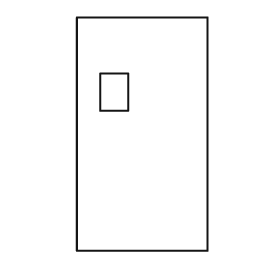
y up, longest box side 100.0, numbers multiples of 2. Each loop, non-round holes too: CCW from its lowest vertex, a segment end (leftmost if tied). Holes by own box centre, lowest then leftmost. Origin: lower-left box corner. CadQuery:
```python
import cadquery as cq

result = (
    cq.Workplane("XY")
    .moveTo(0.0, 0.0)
    .lineTo(56.0, 0.0)
    .lineTo(56.0, 100.0)
    .lineTo(0.0, 100.0)
    .close()
    .moveTo(10.0, 60.0)
    .lineTo(22.0, 60.0)
    .lineTo(22.0, 76.0)
    .lineTo(10.0, 76.0)
    .close()
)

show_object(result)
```